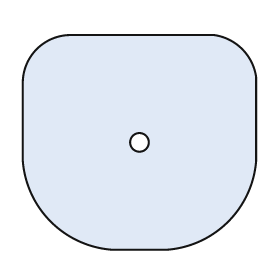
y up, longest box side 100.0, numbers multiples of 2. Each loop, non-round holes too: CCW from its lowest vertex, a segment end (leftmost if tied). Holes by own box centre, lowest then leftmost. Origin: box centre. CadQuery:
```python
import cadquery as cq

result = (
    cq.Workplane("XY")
    .moveTo(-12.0, -46.0)
    .lineTo(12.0, -46.0)
    .threePointArc((38.0, -34.0), (50.0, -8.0))
    .lineTo(50.0, 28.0)
    .threePointArc((44.0, 40.0), (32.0, 46.0))
    .lineTo(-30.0, 46.0)
    .threePointArc((-44.0, 40.0), (-50.0, 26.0))
    .lineTo(-50.0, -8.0)
    .threePointArc((-38.0, -34.0), (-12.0, -46.0))
    .close()
    .moveTo(0.0, 0.0)
    .circle(4.0)
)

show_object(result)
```